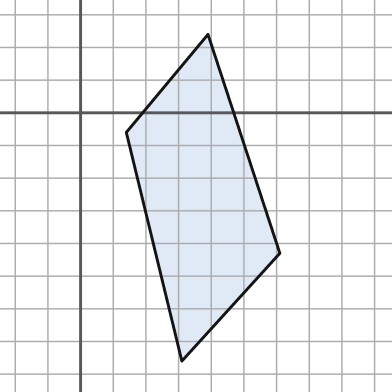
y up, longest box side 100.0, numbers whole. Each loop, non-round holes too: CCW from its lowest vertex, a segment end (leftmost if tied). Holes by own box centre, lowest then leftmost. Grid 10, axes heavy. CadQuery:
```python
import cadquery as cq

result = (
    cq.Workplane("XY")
    .moveTo(31.0, -76.0)
    .lineTo(61.0, -43.0)
    .lineTo(39.0, 24.0)
    .lineTo(14.0, -6.0)
    .close()
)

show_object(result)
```